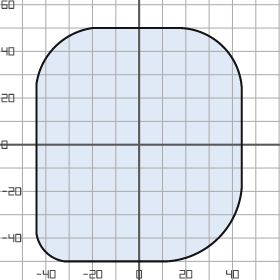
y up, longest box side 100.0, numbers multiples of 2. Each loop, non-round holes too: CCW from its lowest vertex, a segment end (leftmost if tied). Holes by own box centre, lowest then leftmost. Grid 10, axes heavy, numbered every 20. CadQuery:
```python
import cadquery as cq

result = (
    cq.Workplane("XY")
    .moveTo(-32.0, -50.0)
    .lineTo(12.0, -50.0)
    .threePointArc((34.0, -40.0), (44.0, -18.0))
    .lineTo(44.0, 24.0)
    .threePointArc((36.0, 42.0), (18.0, 50.0))
    .lineTo(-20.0, 50.0)
    .threePointArc((-36.0, 42.0), (-44.0, 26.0))
    .lineTo(-44.0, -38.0)
    .threePointArc((-40.0, -46.0), (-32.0, -50.0))
    .close()
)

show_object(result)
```